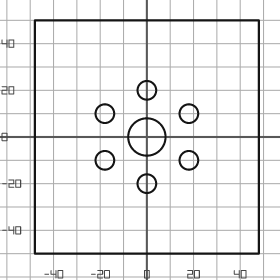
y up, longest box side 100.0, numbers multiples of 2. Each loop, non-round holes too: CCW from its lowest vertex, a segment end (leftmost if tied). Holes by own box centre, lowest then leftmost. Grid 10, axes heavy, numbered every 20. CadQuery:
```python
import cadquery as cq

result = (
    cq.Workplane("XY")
    .moveTo(-48.0, -50.0)
    .lineTo(48.0, -50.0)
    .lineTo(48.0, 50.0)
    .lineTo(-48.0, 50.0)
    .close()
    .moveTo(0.0, -20.0)
    .circle(4.0)
    .moveTo(-18.0, -10.0)
    .circle(4.0)
    .moveTo(18.0, -10.0)
    .circle(4.0)
    .moveTo(0.0, 0.0)
    .circle(8.0)
    .moveTo(-18.0, 10.0)
    .circle(4.0)
    .moveTo(18.0, 10.0)
    .circle(4.0)
    .moveTo(0.0, 20.0)
    .circle(4.0)
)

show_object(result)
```